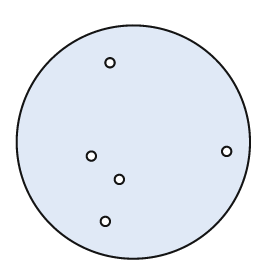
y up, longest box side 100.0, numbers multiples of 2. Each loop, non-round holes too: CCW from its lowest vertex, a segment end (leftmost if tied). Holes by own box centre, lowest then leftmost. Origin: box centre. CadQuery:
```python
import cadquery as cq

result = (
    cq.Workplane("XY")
    .moveTo(0.0, 0.0)
    .circle(50.0)
    .moveTo(-12.0, -34.0)
    .circle(2.0)
    .moveTo(-6.0, -16.0)
    .circle(2.0)
    .moveTo(-18.0, -6.0)
    .circle(2.0)
    .moveTo(40.0, -4.0)
    .circle(2.0)
    .moveTo(-10.0, 34.0)
    .circle(2.0)
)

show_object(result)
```